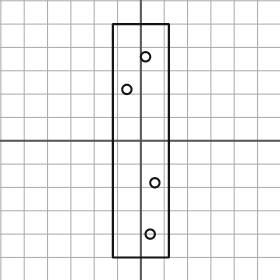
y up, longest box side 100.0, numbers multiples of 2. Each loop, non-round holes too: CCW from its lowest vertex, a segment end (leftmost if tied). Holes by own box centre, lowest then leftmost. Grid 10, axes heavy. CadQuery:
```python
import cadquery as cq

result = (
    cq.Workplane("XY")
    .moveTo(-12.0, -50.0)
    .lineTo(12.0, -50.0)
    .lineTo(12.0, 50.0)
    .lineTo(-12.0, 50.0)
    .close()
    .moveTo(4.0, -40.0)
    .circle(2.0)
    .moveTo(6.0, -18.0)
    .circle(2.0)
    .moveTo(-6.0, 22.0)
    .circle(2.0)
    .moveTo(2.0, 36.0)
    .circle(2.0)
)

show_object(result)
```